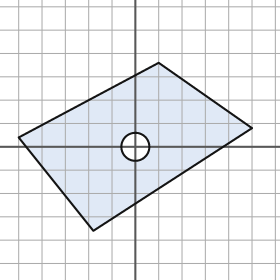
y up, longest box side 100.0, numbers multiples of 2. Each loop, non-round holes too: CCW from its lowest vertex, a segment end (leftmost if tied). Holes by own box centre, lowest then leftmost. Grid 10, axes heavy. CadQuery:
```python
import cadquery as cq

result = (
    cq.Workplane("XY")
    .moveTo(-18.0, -36.0)
    .lineTo(50.0, 8.0)
    .lineTo(10.0, 36.0)
    .lineTo(-50.0, 4.0)
    .close()
    .moveTo(0.0, 0.0)
    .circle(6.0)
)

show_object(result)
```